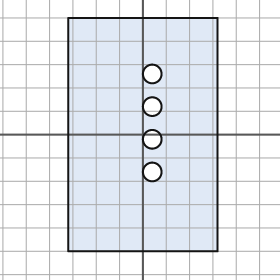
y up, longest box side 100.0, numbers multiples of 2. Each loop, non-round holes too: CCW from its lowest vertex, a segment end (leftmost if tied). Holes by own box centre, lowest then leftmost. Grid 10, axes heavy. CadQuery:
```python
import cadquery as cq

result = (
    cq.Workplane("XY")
    .moveTo(-32.0, -50.0)
    .lineTo(32.0, -50.0)
    .lineTo(32.0, 50.0)
    .lineTo(-32.0, 50.0)
    .close()
    .moveTo(4.0, -16.0)
    .circle(4.0)
    .moveTo(4.0, -2.0)
    .circle(4.0)
    .moveTo(4.0, 12.0)
    .circle(4.0)
    .moveTo(4.0, 26.0)
    .circle(4.0)
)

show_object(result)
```